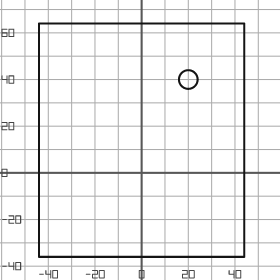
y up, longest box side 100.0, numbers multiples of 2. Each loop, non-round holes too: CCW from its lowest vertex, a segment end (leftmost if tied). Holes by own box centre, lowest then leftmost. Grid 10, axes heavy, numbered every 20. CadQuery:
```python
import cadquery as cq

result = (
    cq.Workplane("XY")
    .moveTo(-44.0, -36.0)
    .lineTo(44.0, -36.0)
    .lineTo(44.0, 64.0)
    .lineTo(-44.0, 64.0)
    .close()
    .moveTo(20.0, 40.0)
    .circle(4.0)
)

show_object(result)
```